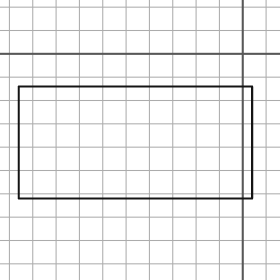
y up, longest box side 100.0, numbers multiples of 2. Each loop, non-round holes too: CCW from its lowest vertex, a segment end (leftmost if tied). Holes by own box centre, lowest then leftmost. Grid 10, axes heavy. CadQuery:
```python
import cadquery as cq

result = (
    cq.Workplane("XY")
    .moveTo(-96.0, -62.0)
    .lineTo(4.0, -62.0)
    .lineTo(4.0, -14.0)
    .lineTo(-96.0, -14.0)
    .close()
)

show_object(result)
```